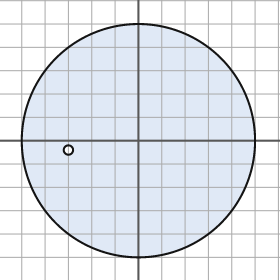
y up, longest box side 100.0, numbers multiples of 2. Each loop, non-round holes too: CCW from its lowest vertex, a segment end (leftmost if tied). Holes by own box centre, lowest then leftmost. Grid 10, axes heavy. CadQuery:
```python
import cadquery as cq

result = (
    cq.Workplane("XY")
    .moveTo(0.0, 0.0)
    .circle(50.0)
    .moveTo(-30.0, -4.0)
    .circle(2.0)
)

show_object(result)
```